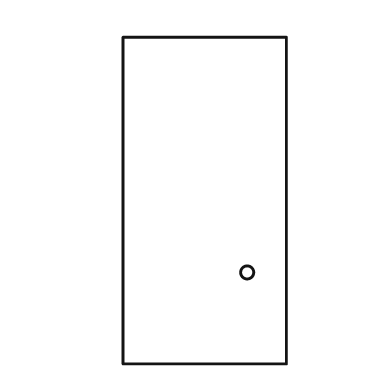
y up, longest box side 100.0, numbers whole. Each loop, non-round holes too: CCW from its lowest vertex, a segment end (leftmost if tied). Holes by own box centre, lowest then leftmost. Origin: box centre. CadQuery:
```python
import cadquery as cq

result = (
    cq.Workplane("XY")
    .moveTo(-25.0, -50.0)
    .lineTo(25.0, -50.0)
    .lineTo(25.0, 50.0)
    .lineTo(-25.0, 50.0)
    .close()
    .moveTo(13.0, -22.0)
    .circle(2.0)
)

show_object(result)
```